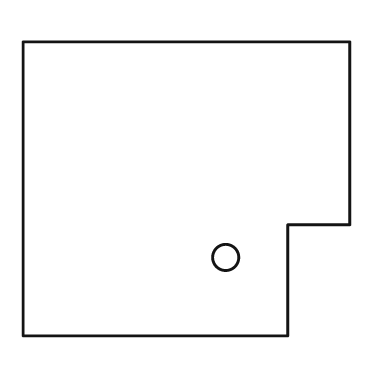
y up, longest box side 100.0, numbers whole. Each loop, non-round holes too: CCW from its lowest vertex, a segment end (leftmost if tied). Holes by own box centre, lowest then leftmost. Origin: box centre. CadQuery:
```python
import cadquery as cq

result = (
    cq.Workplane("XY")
    .moveTo(-50.0, -45.0)
    .lineTo(31.0, -45.0)
    .lineTo(31.0, -11.0)
    .lineTo(50.0, -11.0)
    .lineTo(50.0, 45.0)
    .lineTo(-50.0, 45.0)
    .close()
    .moveTo(12.0, -21.0)
    .circle(4.0)
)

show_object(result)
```